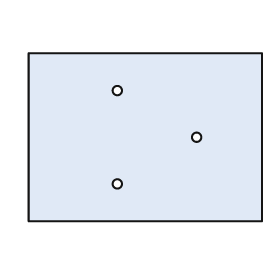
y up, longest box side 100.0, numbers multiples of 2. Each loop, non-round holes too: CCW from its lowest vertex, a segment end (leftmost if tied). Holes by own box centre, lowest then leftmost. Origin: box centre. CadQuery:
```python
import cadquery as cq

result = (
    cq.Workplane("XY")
    .moveTo(-50.0, -36.0)
    .lineTo(50.0, -36.0)
    .lineTo(50.0, 36.0)
    .lineTo(-50.0, 36.0)
    .close()
    .moveTo(-12.0, -20.0)
    .circle(2.0)
    .moveTo(22.0, 0.0)
    .circle(2.0)
    .moveTo(-12.0, 20.0)
    .circle(2.0)
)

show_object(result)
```